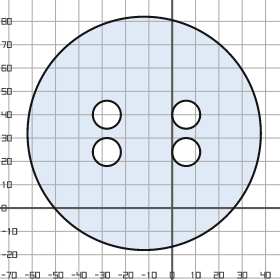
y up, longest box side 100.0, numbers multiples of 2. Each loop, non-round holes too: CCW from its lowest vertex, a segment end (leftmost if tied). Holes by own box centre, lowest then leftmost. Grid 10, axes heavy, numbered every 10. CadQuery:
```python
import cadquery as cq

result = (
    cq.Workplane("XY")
    .moveTo(-12.0, 32.0)
    .circle(50.0)
    .moveTo(-28.0, 24.0)
    .circle(6.0)
    .moveTo(6.0, 24.0)
    .circle(6.0)
    .moveTo(-28.0, 40.0)
    .circle(6.0)
    .moveTo(6.0, 40.0)
    .circle(6.0)
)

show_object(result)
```